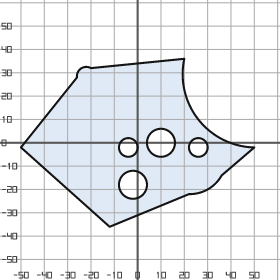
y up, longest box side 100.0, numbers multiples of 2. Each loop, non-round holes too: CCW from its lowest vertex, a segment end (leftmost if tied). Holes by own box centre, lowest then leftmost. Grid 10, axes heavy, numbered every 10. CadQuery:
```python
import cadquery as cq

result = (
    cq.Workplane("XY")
    .moveTo(-12.0, -36.0)
    .lineTo(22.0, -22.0)
    .threePointArc((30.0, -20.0), (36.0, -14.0))
    .lineTo(50.0, -2.0)
    .threePointArc((26.0, 10.0), (20.0, 36.0))
    .lineTo(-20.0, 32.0)
    .threePointArc((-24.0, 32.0), (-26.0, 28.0))
    .lineTo(-50.0, -2.0)
    .close()
    .moveTo(-2.0, -18.0)
    .circle(6.0)
    .moveTo(-4.0, -2.0)
    .circle(4.0)
    .moveTo(26.0, -2.0)
    .circle(4.0)
    .moveTo(10.0, 0.0)
    .circle(6.0)
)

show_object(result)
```